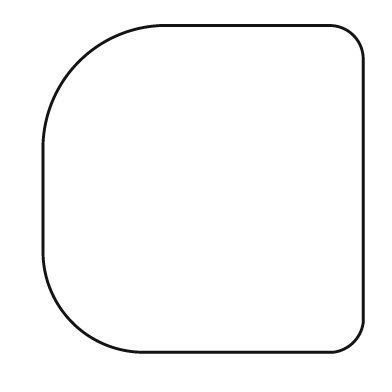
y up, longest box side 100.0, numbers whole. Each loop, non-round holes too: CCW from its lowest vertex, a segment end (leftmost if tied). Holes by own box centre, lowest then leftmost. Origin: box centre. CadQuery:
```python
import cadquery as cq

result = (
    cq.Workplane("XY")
    .moveTo(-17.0, -50.0)
    .lineTo(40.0, -50.0)
    .threePointArc((46.0, -47.0), (49.0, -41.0))
    .lineTo(49.0, 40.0)
    .threePointArc((46.0, 47.0), (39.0, 50.0))
    .lineTo(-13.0, 50.0)
    .threePointArc((-38.0, 39.0), (-49.0, 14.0))
    .lineTo(-49.0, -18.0)
    .threePointArc((-40.0, -41.0), (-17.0, -50.0))
    .close()
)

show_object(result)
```